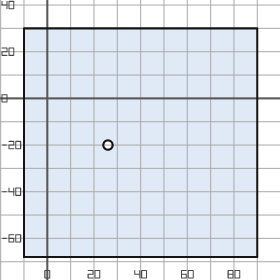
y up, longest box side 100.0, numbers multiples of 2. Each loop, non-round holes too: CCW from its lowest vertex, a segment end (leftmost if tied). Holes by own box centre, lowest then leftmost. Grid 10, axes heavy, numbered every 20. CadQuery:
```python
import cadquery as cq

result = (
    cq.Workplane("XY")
    .moveTo(-10.0, -68.0)
    .lineTo(90.0, -68.0)
    .lineTo(90.0, 30.0)
    .lineTo(-10.0, 30.0)
    .close()
    .moveTo(26.0, -20.0)
    .circle(2.0)
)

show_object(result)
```